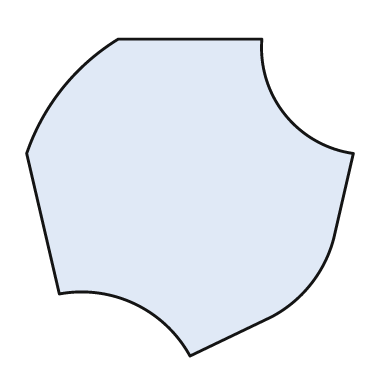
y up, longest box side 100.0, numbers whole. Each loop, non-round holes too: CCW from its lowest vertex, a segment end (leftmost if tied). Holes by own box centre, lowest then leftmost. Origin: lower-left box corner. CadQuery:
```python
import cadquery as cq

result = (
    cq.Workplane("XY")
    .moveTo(50.0, 0.0)
    .lineTo(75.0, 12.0)
    .threePointArc((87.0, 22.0), (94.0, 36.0))
    .lineTo(100.0, 62.0)
    .threePointArc((79.0, 74.0), (72.0, 97.0))
    .lineTo(28.0, 97.0)
    .threePointArc((11.0, 82.0), (0.0, 62.0))
    .lineTo(10.0, 19.0)
    .threePointArc((33.0, 16.0), (50.0, 0.0))
    .close()
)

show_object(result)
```